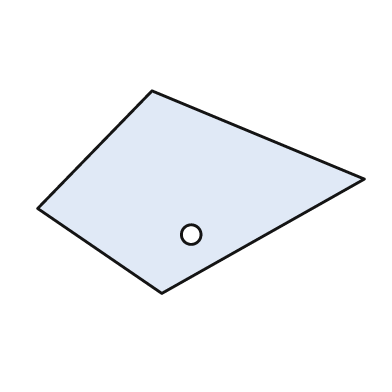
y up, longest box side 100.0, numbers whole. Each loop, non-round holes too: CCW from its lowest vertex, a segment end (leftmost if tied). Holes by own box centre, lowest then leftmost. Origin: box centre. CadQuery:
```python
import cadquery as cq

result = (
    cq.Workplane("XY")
    .moveTo(-12.0, -31.0)
    .lineTo(50.0, 4.0)
    .lineTo(-15.0, 31.0)
    .lineTo(-50.0, -5.0)
    .close()
    .moveTo(-3.0, -13.0)
    .circle(3.0)
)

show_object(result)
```